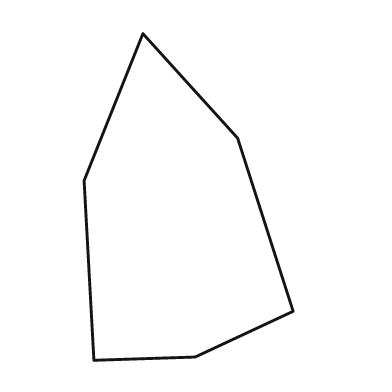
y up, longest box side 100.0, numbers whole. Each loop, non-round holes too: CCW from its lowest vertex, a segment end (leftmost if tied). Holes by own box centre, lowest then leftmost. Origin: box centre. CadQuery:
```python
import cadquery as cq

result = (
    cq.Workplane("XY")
    .moveTo(-29.0, -50.0)
    .lineTo(2.0, -49.0)
    .lineTo(32.0, -35.0)
    .lineTo(15.0, 18.0)
    .lineTo(-14.0, 50.0)
    .lineTo(-32.0, 5.0)
    .close()
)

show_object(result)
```